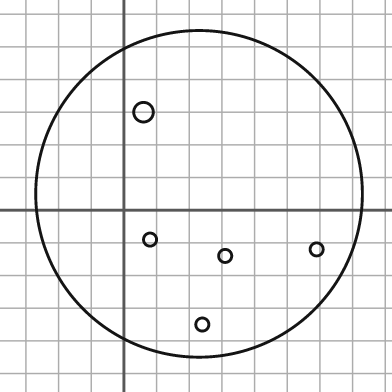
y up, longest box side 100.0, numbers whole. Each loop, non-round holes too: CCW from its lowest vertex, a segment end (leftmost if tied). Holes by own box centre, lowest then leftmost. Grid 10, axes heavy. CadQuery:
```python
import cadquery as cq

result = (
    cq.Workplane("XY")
    .moveTo(23.0, 5.0)
    .circle(50.0)
    .moveTo(24.0, -35.0)
    .circle(2.0)
    .moveTo(31.0, -14.0)
    .circle(2.0)
    .moveTo(59.0, -12.0)
    .circle(2.0)
    .moveTo(8.0, -9.0)
    .circle(2.0)
    .moveTo(6.0, 30.0)
    .circle(3.0)
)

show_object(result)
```